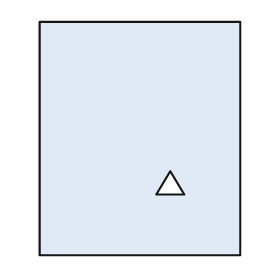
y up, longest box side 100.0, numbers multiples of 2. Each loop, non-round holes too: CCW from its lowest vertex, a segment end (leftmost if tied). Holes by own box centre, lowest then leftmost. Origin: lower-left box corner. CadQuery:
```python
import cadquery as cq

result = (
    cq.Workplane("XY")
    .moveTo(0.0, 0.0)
    .lineTo(86.0, 0.0)
    .lineTo(86.0, 100.0)
    .lineTo(0.0, 100.0)
    .close()
    .moveTo(50.0, 26.0)
    .lineTo(62.0, 26.0)
    .lineTo(56.0, 36.0)
    .close()
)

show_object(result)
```